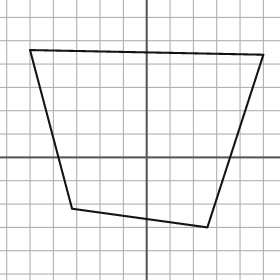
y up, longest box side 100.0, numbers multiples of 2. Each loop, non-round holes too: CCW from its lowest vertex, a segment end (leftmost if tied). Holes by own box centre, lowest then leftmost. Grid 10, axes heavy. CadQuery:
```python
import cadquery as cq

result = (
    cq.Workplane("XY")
    .moveTo(26.0, -30.0)
    .lineTo(50.0, 44.0)
    .lineTo(-50.0, 46.0)
    .lineTo(-32.0, -22.0)
    .close()
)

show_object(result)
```